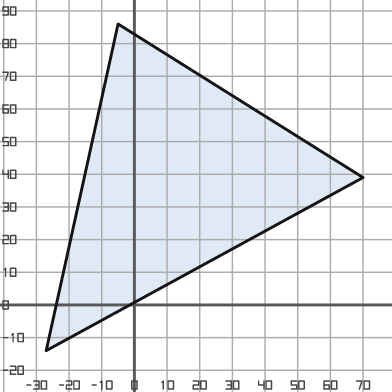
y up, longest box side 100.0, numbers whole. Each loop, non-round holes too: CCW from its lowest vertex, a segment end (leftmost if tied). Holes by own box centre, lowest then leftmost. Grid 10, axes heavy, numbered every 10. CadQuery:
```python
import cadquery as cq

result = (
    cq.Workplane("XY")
    .moveTo(-27.0, -14.0)
    .lineTo(70.0, 39.0)
    .lineTo(-5.0, 86.0)
    .close()
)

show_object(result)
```